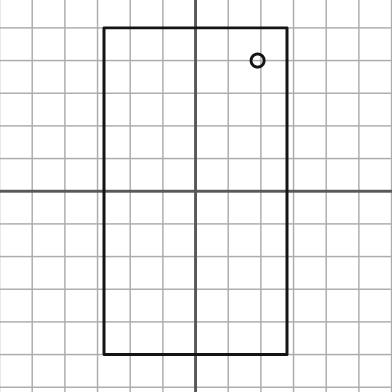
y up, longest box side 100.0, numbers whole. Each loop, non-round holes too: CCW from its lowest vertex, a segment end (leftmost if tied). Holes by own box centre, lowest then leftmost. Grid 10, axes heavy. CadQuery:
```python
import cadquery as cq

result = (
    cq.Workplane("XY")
    .moveTo(-28.0, -50.0)
    .lineTo(28.0, -50.0)
    .lineTo(28.0, 50.0)
    .lineTo(-28.0, 50.0)
    .close()
    .moveTo(19.0, 40.0)
    .circle(2.0)
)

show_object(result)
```